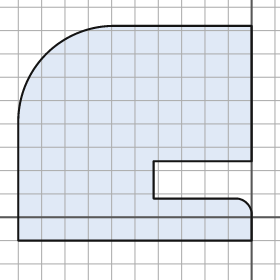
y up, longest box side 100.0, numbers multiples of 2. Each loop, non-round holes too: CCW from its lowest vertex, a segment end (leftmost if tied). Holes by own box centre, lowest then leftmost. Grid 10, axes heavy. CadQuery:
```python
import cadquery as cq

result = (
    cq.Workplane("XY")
    .moveTo(-100.0, -10.0)
    .lineTo(0.0, -10.0)
    .lineTo(0.0, 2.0)
    .threePointArc((-2.0, 6.0), (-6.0, 8.0))
    .lineTo(-42.0, 8.0)
    .lineTo(-42.0, 24.0)
    .lineTo(0.0, 24.0)
    .lineTo(0.0, 82.0)
    .lineTo(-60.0, 82.0)
    .threePointArc((-88.0, 70.0), (-100.0, 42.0))
    .close()
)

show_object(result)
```